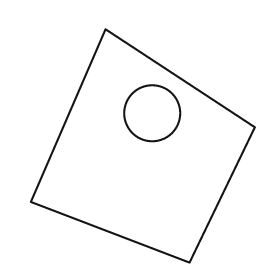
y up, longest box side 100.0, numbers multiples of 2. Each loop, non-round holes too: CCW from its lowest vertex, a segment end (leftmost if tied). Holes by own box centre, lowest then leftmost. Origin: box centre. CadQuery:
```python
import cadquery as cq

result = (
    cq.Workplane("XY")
    .moveTo(20.0, -50.0)
    .lineTo(48.0, 8.0)
    .lineTo(-16.0, 50.0)
    .lineTo(-48.0, -24.0)
    .close()
    .moveTo(4.0, 14.0)
    .circle(12.0)
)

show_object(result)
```